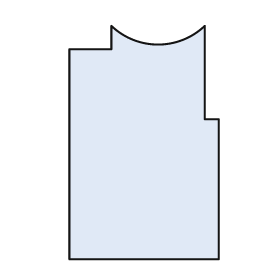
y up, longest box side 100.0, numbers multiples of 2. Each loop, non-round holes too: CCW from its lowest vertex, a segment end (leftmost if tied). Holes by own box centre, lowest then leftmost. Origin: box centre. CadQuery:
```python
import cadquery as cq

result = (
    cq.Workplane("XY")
    .moveTo(-32.0, -50.0)
    .lineTo(32.0, -50.0)
    .lineTo(32.0, 10.0)
    .lineTo(26.0, 10.0)
    .lineTo(26.0, 50.0)
    .threePointArc((6.0, 42.0), (-14.0, 50.0))
    .lineTo(-14.0, 40.0)
    .lineTo(-32.0, 40.0)
    .close()
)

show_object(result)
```